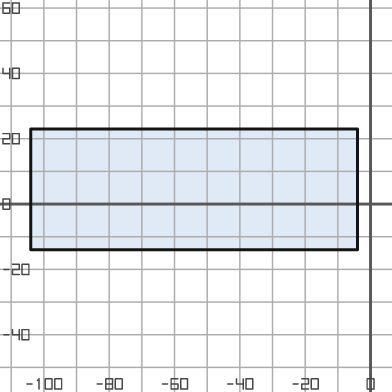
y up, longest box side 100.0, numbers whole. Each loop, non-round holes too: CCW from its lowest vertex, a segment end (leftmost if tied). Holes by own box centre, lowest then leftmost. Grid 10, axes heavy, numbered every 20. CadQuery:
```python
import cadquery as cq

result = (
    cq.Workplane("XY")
    .moveTo(-104.0, -14.0)
    .lineTo(-4.0, -14.0)
    .lineTo(-4.0, 23.0)
    .lineTo(-104.0, 23.0)
    .close()
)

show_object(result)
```